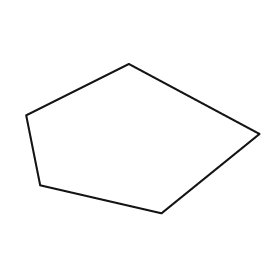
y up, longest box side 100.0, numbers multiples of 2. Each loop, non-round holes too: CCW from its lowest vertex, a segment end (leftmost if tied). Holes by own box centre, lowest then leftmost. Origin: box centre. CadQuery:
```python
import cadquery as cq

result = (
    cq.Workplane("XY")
    .moveTo(8.0, -32.0)
    .lineTo(50.0, 2.0)
    .lineTo(-6.0, 32.0)
    .lineTo(-50.0, 10.0)
    .lineTo(-44.0, -20.0)
    .close()
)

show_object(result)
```